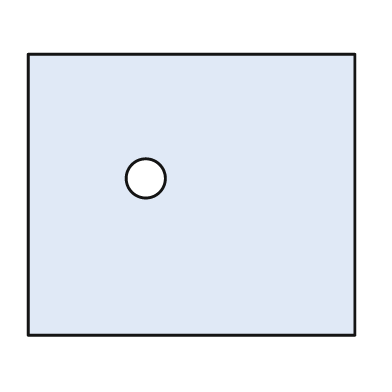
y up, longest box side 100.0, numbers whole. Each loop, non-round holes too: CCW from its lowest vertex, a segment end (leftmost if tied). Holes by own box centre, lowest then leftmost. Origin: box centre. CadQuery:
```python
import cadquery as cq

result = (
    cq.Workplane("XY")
    .moveTo(-50.0, -43.0)
    .lineTo(50.0, -43.0)
    .lineTo(50.0, 43.0)
    .lineTo(-50.0, 43.0)
    .close()
    .moveTo(-14.0, 5.0)
    .circle(6.0)
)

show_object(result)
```